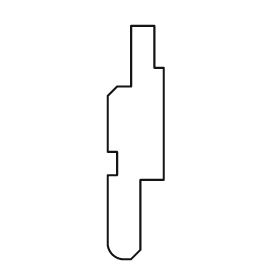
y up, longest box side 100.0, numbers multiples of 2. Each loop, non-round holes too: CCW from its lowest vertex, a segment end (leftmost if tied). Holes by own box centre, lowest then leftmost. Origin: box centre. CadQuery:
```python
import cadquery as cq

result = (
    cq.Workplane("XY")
    .moveTo(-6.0, -50.0)
    .lineTo(-2.0, -50.0)
    .lineTo(2.0, -46.0)
    .lineTo(2.0, -16.0)
    .lineTo(12.0, -16.0)
    .lineTo(12.0, 32.0)
    .lineTo(8.0, 32.0)
    .lineTo(8.0, 50.0)
    .lineTo(-2.0, 50.0)
    .lineTo(-2.0, 24.0)
    .lineTo(-8.0, 24.0)
    .lineTo(-12.0, 20.0)
    .lineTo(-12.0, -4.0)
    .lineTo(-8.0, -4.0)
    .lineTo(-8.0, -14.0)
    .lineTo(-12.0, -14.0)
    .lineTo(-12.0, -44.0)
    .threePointArc((-10.0, -48.0), (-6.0, -50.0))
    .close()
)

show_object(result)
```